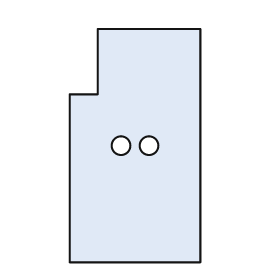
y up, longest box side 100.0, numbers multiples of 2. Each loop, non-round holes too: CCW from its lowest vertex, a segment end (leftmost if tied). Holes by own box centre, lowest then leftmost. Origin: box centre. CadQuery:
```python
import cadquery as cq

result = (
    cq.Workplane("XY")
    .moveTo(-28.0, -50.0)
    .lineTo(28.0, -50.0)
    .lineTo(28.0, 50.0)
    .lineTo(-16.0, 50.0)
    .lineTo(-16.0, 22.0)
    .lineTo(-28.0, 22.0)
    .close()
    .moveTo(-6.0, 0.0)
    .circle(4.0)
    .moveTo(6.0, 0.0)
    .circle(4.0)
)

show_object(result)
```